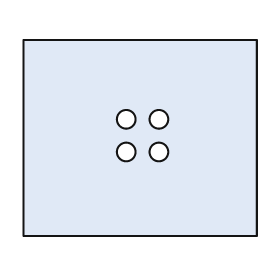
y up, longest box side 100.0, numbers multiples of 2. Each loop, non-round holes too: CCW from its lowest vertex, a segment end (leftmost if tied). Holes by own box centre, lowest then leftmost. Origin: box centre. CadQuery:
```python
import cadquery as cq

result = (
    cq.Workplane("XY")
    .moveTo(-50.0, -42.0)
    .lineTo(50.0, -42.0)
    .lineTo(50.0, 42.0)
    .lineTo(-50.0, 42.0)
    .close()
    .moveTo(-6.0, -6.0)
    .circle(4.0)
    .moveTo(8.0, -6.0)
    .circle(4.0)
    .moveTo(-6.0, 8.0)
    .circle(4.0)
    .moveTo(8.0, 8.0)
    .circle(4.0)
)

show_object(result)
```